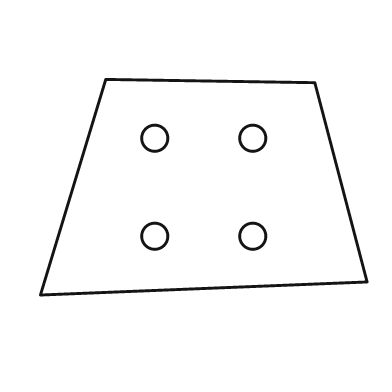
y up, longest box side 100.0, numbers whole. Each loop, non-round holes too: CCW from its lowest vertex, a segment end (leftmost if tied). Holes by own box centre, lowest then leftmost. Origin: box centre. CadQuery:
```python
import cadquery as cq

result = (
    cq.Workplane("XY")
    .moveTo(-50.0, -33.0)
    .lineTo(50.0, -29.0)
    .lineTo(34.0, 32.0)
    .lineTo(-30.0, 33.0)
    .close()
    .moveTo(-15.0, -15.0)
    .circle(4.0)
    .moveTo(15.0, -15.0)
    .circle(4.0)
    .moveTo(-15.0, 15.0)
    .circle(4.0)
    .moveTo(15.0, 15.0)
    .circle(4.0)
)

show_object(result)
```